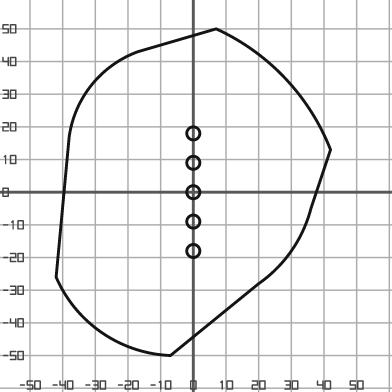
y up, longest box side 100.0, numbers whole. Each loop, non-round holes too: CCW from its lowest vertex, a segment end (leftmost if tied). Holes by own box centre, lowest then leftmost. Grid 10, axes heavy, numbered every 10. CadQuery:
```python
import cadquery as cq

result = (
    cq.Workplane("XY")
    .moveTo(-7.0, -50.0)
    .lineTo(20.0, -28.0)
    .threePointArc((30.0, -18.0), (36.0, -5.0))
    .lineTo(42.0, 13.0)
    .threePointArc((28.0, 35.0), (7.0, 50.0))
    .lineTo(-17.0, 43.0)
    .threePointArc((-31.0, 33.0), (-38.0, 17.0))
    .lineTo(-42.0, -26.0)
    .threePointArc((-28.0, -43.0), (-7.0, -50.0))
    .close()
    .moveTo(0.0, -18.0)
    .circle(2.0)
    .moveTo(0.0, -9.0)
    .circle(2.0)
    .moveTo(0.0, 0.0)
    .circle(2.0)
    .moveTo(0.0, 9.0)
    .circle(2.0)
    .moveTo(0.0, 18.0)
    .circle(2.0)
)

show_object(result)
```